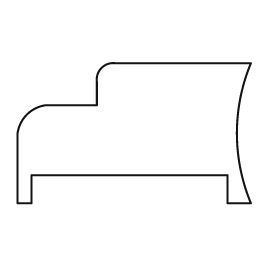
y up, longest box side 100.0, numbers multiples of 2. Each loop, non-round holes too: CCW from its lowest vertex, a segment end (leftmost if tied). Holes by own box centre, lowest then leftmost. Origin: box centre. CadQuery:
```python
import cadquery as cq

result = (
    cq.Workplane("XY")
    .moveTo(-50.0, -30.0)
    .lineTo(-44.0, -30.0)
    .lineTo(-44.0, -18.0)
    .lineTo(40.0, -18.0)
    .lineTo(40.0, -30.0)
    .lineTo(50.0, -30.0)
    .threePointArc((44.0, 0.0), (50.0, 30.0))
    .lineTo(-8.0, 30.0)
    .threePointArc((-14.0, 28.0), (-16.0, 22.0))
    .lineTo(-16.0, 12.0)
    .lineTo(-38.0, 12.0)
    .threePointArc((-46.0, 8.0), (-50.0, 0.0))
    .close()
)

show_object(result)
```